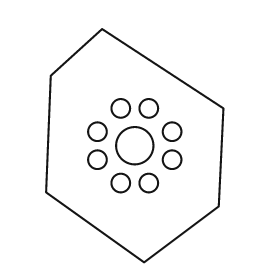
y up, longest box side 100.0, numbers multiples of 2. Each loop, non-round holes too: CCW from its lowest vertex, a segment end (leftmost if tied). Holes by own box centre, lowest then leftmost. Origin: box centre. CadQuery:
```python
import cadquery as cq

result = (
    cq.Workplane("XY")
    .moveTo(4.0, -50.0)
    .lineTo(36.0, -26.0)
    .lineTo(38.0, 16.0)
    .lineTo(-14.0, 50.0)
    .lineTo(-36.0, 30.0)
    .lineTo(-38.0, -20.0)
    .close()
    .moveTo(-6.0, -16.0)
    .circle(4.0)
    .moveTo(6.0, -16.0)
    .circle(4.0)
    .moveTo(-16.0, -6.0)
    .circle(4.0)
    .moveTo(16.0, -6.0)
    .circle(4.0)
    .moveTo(0.0, 0.0)
    .circle(8.0)
    .moveTo(-16.0, 6.0)
    .circle(4.0)
    .moveTo(16.0, 6.0)
    .circle(4.0)
    .moveTo(-6.0, 16.0)
    .circle(4.0)
    .moveTo(6.0, 16.0)
    .circle(4.0)
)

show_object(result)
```